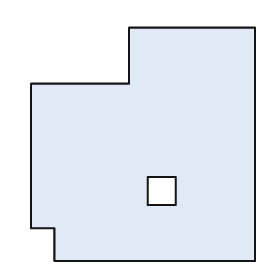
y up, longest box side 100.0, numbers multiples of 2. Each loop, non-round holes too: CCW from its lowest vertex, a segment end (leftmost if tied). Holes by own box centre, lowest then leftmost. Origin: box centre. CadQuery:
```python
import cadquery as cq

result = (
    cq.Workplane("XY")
    .moveTo(-38.0, -50.0)
    .lineTo(48.0, -50.0)
    .lineTo(48.0, 50.0)
    .lineTo(-6.0, 50.0)
    .lineTo(-6.0, 26.0)
    .lineTo(-48.0, 26.0)
    .lineTo(-48.0, -36.0)
    .lineTo(-38.0, -36.0)
    .close()
    .moveTo(2.0, -26.0)
    .lineTo(14.0, -26.0)
    .lineTo(14.0, -14.0)
    .lineTo(2.0, -14.0)
    .close()
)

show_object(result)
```